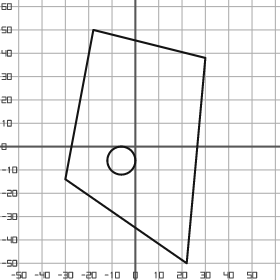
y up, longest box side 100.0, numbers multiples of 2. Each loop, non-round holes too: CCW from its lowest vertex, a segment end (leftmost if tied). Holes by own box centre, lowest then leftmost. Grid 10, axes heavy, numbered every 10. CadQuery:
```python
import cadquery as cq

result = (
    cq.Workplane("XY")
    .moveTo(22.0, -50.0)
    .lineTo(30.0, 38.0)
    .lineTo(-18.0, 50.0)
    .lineTo(-30.0, -14.0)
    .close()
    .moveTo(-6.0, -6.0)
    .circle(6.0)
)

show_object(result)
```